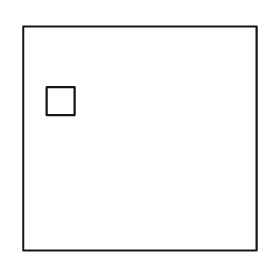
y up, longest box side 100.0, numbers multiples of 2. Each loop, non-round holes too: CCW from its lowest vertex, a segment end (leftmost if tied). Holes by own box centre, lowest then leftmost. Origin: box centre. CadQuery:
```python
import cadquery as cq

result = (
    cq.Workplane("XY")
    .moveTo(-50.0, -48.0)
    .lineTo(50.0, -48.0)
    .lineTo(50.0, 48.0)
    .lineTo(-50.0, 48.0)
    .close()
    .moveTo(-40.0, 10.0)
    .lineTo(-28.0, 10.0)
    .lineTo(-28.0, 22.0)
    .lineTo(-40.0, 22.0)
    .close()
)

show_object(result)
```